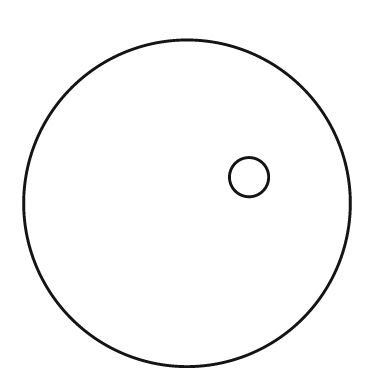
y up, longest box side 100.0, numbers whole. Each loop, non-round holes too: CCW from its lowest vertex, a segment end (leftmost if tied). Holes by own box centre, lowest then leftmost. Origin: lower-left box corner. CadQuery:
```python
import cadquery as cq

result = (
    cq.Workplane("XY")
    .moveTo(50.0, 50.0)
    .circle(50.0)
    .moveTo(69.0, 58.0)
    .circle(6.0)
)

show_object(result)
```